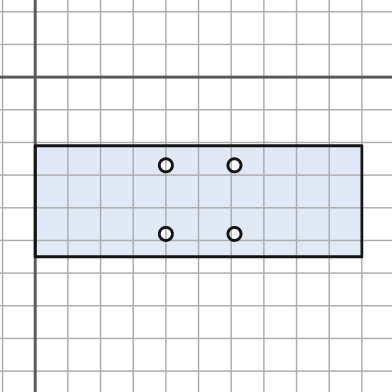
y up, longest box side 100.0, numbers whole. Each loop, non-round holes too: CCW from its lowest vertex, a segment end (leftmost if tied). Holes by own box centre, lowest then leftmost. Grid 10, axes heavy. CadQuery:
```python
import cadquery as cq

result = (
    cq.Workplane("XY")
    .moveTo(0.0, -55.0)
    .lineTo(100.0, -55.0)
    .lineTo(100.0, -21.0)
    .lineTo(0.0, -21.0)
    .close()
    .moveTo(40.0, -48.0)
    .circle(2.0)
    .moveTo(61.0, -48.0)
    .circle(2.0)
    .moveTo(40.0, -27.0)
    .circle(2.0)
    .moveTo(61.0, -27.0)
    .circle(2.0)
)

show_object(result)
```